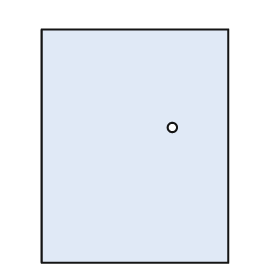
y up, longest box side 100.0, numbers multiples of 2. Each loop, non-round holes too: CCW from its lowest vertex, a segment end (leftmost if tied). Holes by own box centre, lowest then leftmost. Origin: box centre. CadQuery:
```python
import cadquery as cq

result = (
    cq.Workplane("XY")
    .moveTo(-40.0, -50.0)
    .lineTo(40.0, -50.0)
    .lineTo(40.0, 50.0)
    .lineTo(-40.0, 50.0)
    .close()
    .moveTo(16.0, 8.0)
    .circle(2.0)
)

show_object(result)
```